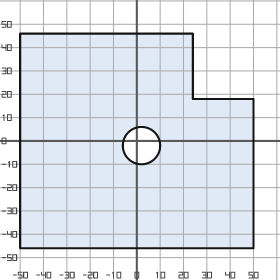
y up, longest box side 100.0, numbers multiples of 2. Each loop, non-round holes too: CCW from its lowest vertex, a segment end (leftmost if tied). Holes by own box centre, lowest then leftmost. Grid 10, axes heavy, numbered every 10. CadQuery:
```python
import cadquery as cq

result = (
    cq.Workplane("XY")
    .moveTo(-50.0, -46.0)
    .lineTo(50.0, -46.0)
    .lineTo(50.0, 18.0)
    .lineTo(24.0, 18.0)
    .lineTo(24.0, 46.0)
    .lineTo(-50.0, 46.0)
    .close()
    .moveTo(2.0, -2.0)
    .circle(8.0)
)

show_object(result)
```